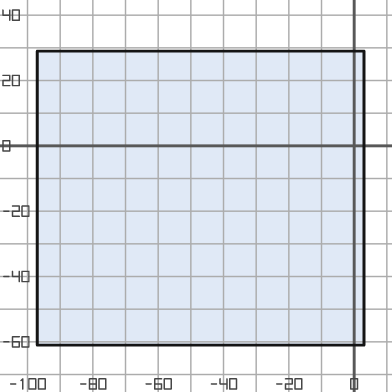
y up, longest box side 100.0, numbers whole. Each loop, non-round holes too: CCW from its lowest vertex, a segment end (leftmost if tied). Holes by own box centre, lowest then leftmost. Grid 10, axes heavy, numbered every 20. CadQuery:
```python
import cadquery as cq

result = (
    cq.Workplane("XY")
    .moveTo(-97.0, -61.0)
    .lineTo(3.0, -61.0)
    .lineTo(3.0, 29.0)
    .lineTo(-97.0, 29.0)
    .close()
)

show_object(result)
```